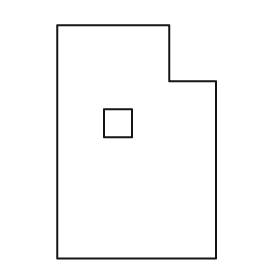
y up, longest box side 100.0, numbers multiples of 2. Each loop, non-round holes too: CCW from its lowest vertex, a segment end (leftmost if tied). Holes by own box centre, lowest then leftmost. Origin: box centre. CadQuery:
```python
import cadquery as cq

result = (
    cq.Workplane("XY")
    .moveTo(-34.0, -50.0)
    .lineTo(34.0, -50.0)
    .lineTo(34.0, 26.0)
    .lineTo(14.0, 26.0)
    .lineTo(14.0, 50.0)
    .lineTo(-34.0, 50.0)
    .close()
    .moveTo(-14.0, 2.0)
    .lineTo(-2.0, 2.0)
    .lineTo(-2.0, 14.0)
    .lineTo(-14.0, 14.0)
    .close()
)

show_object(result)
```